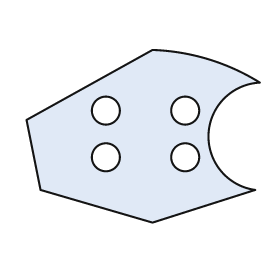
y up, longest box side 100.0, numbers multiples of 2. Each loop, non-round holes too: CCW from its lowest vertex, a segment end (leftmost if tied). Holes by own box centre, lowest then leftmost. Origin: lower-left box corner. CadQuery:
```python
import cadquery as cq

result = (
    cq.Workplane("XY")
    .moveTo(54.0, 0.0)
    .lineTo(98.0, 14.0)
    .threePointArc((78.0, 38.0), (100.0, 60.0))
    .threePointArc((78.0, 70.0), (54.0, 74.0))
    .lineTo(0.0, 44.0)
    .lineTo(6.0, 14.0)
    .close()
    .moveTo(34.0, 28.0)
    .circle(6.0)
    .moveTo(68.0, 28.0)
    .circle(6.0)
    .moveTo(34.0, 48.0)
    .circle(6.0)
    .moveTo(68.0, 48.0)
    .circle(6.0)
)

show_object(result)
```